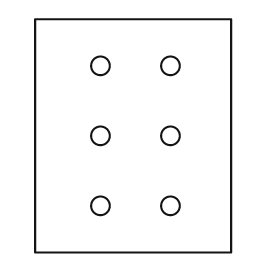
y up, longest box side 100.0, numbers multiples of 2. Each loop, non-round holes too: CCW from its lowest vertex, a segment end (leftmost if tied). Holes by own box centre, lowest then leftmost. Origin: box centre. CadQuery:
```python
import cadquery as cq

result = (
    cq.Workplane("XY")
    .moveTo(-42.0, -50.0)
    .lineTo(42.0, -50.0)
    .lineTo(42.0, 50.0)
    .lineTo(-42.0, 50.0)
    .close()
    .moveTo(-14.0, -30.0)
    .circle(4.0)
    .moveTo(16.0, -30.0)
    .circle(4.0)
    .moveTo(-14.0, 0.0)
    .circle(4.0)
    .moveTo(16.0, 0.0)
    .circle(4.0)
    .moveTo(-14.0, 30.0)
    .circle(4.0)
    .moveTo(16.0, 30.0)
    .circle(4.0)
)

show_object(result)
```